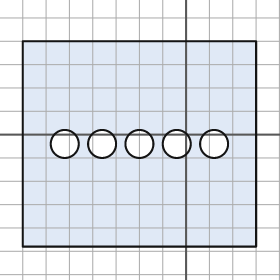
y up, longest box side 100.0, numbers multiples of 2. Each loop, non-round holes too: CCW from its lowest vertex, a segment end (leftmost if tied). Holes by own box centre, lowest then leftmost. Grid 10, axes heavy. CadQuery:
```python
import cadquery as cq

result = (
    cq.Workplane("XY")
    .moveTo(-70.0, -48.0)
    .lineTo(30.0, -48.0)
    .lineTo(30.0, 40.0)
    .lineTo(-70.0, 40.0)
    .close()
    .moveTo(-52.0, -4.0)
    .circle(6.0)
    .moveTo(-36.0, -4.0)
    .circle(6.0)
    .moveTo(-20.0, -4.0)
    .circle(6.0)
    .moveTo(-4.0, -4.0)
    .circle(6.0)
    .moveTo(12.0, -4.0)
    .circle(6.0)
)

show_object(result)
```